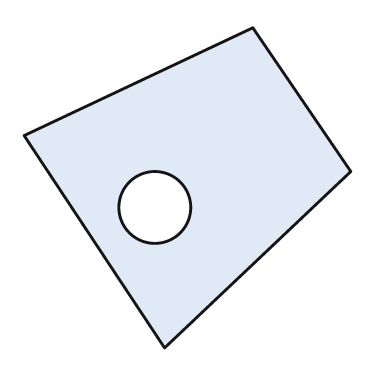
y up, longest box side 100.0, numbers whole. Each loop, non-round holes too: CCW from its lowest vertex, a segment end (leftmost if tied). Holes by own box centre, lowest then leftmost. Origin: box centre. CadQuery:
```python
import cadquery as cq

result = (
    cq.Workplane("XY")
    .moveTo(-7.0, -49.0)
    .lineTo(50.0, 5.0)
    .lineTo(20.0, 49.0)
    .lineTo(-50.0, 16.0)
    .close()
    .moveTo(-10.0, -6.0)
    .circle(11.0)
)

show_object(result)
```